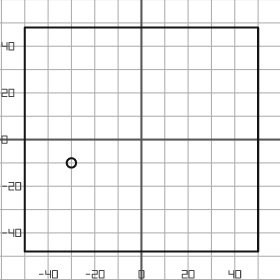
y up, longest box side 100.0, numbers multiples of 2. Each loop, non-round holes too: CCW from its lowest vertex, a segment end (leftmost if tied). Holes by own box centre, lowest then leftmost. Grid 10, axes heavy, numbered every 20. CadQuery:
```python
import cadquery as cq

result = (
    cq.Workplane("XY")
    .moveTo(-50.0, -48.0)
    .lineTo(50.0, -48.0)
    .lineTo(50.0, 48.0)
    .lineTo(-50.0, 48.0)
    .close()
    .moveTo(-30.0, -10.0)
    .circle(2.0)
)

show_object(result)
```